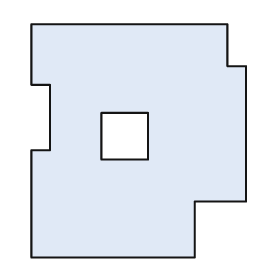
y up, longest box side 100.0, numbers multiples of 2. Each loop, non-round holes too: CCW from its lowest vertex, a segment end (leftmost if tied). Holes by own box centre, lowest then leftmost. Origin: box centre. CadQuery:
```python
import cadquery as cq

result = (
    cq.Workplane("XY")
    .moveTo(-46.0, -50.0)
    .lineTo(24.0, -50.0)
    .lineTo(24.0, -26.0)
    .lineTo(46.0, -26.0)
    .lineTo(46.0, 32.0)
    .lineTo(38.0, 32.0)
    .lineTo(38.0, 50.0)
    .lineTo(-46.0, 50.0)
    .lineTo(-46.0, 24.0)
    .lineTo(-38.0, 24.0)
    .lineTo(-38.0, -4.0)
    .lineTo(-46.0, -4.0)
    .close()
    .moveTo(-16.0, -8.0)
    .lineTo(4.0, -8.0)
    .lineTo(4.0, 12.0)
    .lineTo(-16.0, 12.0)
    .close()
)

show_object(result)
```